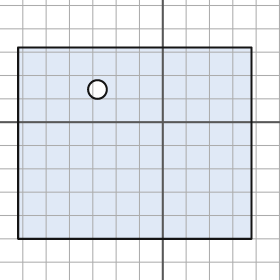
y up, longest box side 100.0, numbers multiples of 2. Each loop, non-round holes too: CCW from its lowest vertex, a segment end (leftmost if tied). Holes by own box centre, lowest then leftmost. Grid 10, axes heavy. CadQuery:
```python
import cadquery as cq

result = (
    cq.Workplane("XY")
    .moveTo(-62.0, -50.0)
    .lineTo(38.0, -50.0)
    .lineTo(38.0, 32.0)
    .lineTo(-62.0, 32.0)
    .close()
    .moveTo(-28.0, 14.0)
    .circle(4.0)
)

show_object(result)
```